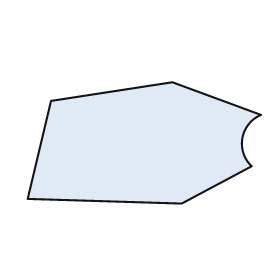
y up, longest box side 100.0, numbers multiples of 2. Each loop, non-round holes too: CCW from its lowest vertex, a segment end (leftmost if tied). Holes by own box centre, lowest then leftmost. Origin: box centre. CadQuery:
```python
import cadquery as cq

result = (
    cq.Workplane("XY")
    .moveTo(16.0, -26.0)
    .lineTo(46.0, -10.0)
    .threePointArc((42.0, 2.0), (50.0, 12.0))
    .lineTo(12.0, 26.0)
    .lineTo(-40.0, 18.0)
    .lineTo(-50.0, -24.0)
    .close()
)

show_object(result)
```